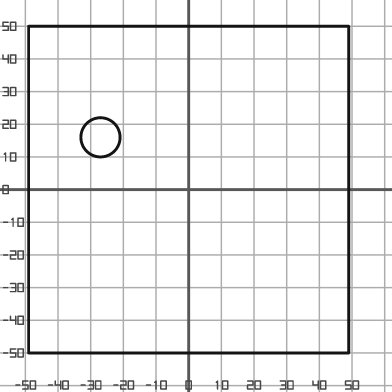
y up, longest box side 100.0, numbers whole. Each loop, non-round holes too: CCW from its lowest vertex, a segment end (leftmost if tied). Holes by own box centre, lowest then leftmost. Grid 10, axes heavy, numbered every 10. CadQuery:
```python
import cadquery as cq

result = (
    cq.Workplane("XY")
    .moveTo(-49.0, -50.0)
    .lineTo(49.0, -50.0)
    .lineTo(49.0, 50.0)
    .lineTo(-49.0, 50.0)
    .close()
    .moveTo(-27.0, 16.0)
    .circle(6.0)
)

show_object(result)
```